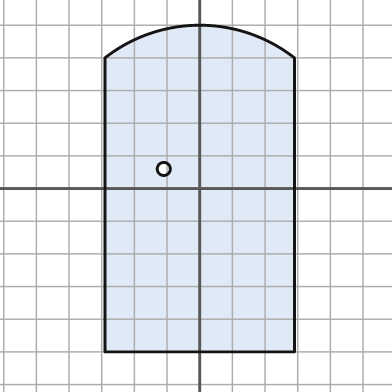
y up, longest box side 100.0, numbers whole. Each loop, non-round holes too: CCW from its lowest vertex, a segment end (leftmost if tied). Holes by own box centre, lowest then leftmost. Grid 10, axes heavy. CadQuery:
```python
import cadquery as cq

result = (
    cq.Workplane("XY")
    .moveTo(-29.0, -50.0)
    .lineTo(29.0, -50.0)
    .lineTo(29.0, 40.0)
    .threePointArc((0.0, 50.0), (-29.0, 40.0))
    .close()
    .moveTo(-11.0, 6.0)
    .circle(2.0)
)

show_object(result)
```